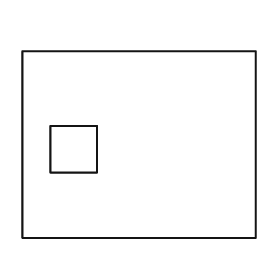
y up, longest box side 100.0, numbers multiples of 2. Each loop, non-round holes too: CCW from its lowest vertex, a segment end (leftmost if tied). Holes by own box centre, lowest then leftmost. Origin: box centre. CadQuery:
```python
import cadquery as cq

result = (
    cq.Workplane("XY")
    .moveTo(-50.0, -40.0)
    .lineTo(50.0, -40.0)
    .lineTo(50.0, 40.0)
    .lineTo(-50.0, 40.0)
    .close()
    .moveTo(-38.0, -12.0)
    .lineTo(-18.0, -12.0)
    .lineTo(-18.0, 8.0)
    .lineTo(-38.0, 8.0)
    .close()
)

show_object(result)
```